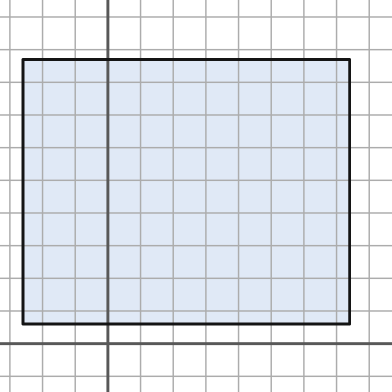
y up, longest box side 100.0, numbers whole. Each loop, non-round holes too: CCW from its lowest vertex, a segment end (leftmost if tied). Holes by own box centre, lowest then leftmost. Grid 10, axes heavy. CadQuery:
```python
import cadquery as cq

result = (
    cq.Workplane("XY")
    .moveTo(-26.0, 6.0)
    .lineTo(74.0, 6.0)
    .lineTo(74.0, 87.0)
    .lineTo(-26.0, 87.0)
    .close()
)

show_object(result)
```